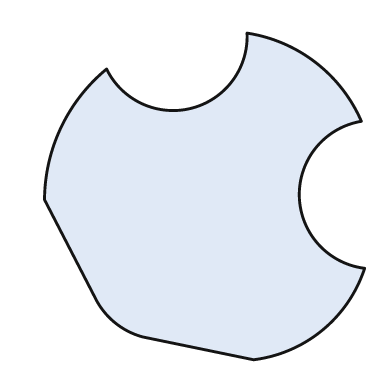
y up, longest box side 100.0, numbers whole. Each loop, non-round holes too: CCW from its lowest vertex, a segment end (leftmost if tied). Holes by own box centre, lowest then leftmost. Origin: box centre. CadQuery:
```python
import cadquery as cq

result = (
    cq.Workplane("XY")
    .moveTo(15.0, -50.0)
    .threePointArc((36.0, -41.0), (49.0, -22.0))
    .threePointArc((29.0, 0.0), (48.0, 23.0))
    .threePointArc((34.0, 41.0), (13.0, 50.0))
    .threePointArc((-4.0, 27.0), (-30.0, 39.0))
    .threePointArc((-44.0, 21.0), (-49.0, -1.0))
    .lineTo(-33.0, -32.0)
    .threePointArc((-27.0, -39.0), (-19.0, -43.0))
    .close()
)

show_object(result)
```